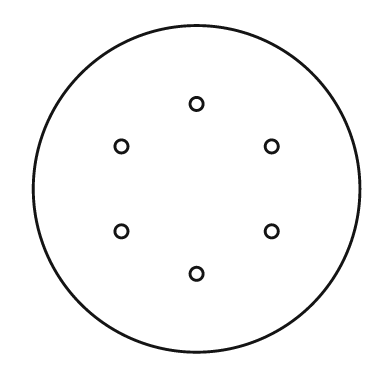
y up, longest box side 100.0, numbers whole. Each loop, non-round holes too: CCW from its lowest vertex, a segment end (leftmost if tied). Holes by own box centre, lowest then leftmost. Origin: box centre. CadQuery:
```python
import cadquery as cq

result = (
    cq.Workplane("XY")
    .moveTo(0.0, 0.0)
    .circle(50.0)
    .moveTo(0.0, -26.0)
    .circle(2.0)
    .moveTo(-23.0, -13.0)
    .circle(2.0)
    .moveTo(23.0, -13.0)
    .circle(2.0)
    .moveTo(-23.0, 13.0)
    .circle(2.0)
    .moveTo(23.0, 13.0)
    .circle(2.0)
    .moveTo(0.0, 26.0)
    .circle(2.0)
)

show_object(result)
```